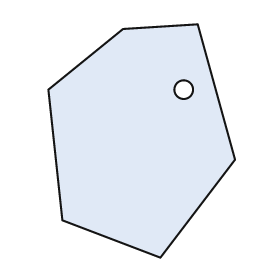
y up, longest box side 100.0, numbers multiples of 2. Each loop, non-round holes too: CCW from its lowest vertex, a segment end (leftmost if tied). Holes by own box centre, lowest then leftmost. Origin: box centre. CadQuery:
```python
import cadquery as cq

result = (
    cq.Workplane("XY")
    .moveTo(8.0, -50.0)
    .lineTo(40.0, -8.0)
    .lineTo(24.0, 50.0)
    .lineTo(-8.0, 48.0)
    .lineTo(-40.0, 22.0)
    .lineTo(-34.0, -34.0)
    .close()
    .moveTo(18.0, 22.0)
    .circle(4.0)
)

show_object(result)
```